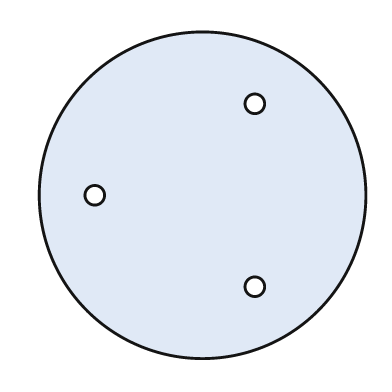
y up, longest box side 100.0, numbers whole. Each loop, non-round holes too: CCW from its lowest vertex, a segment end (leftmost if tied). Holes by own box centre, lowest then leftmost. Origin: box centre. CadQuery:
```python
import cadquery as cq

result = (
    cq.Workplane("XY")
    .moveTo(0.0, 0.0)
    .circle(50.0)
    .moveTo(16.0, -28.0)
    .circle(3.0)
    .moveTo(-33.0, 0.0)
    .circle(3.0)
    .moveTo(16.0, 28.0)
    .circle(3.0)
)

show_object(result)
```